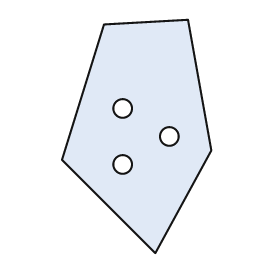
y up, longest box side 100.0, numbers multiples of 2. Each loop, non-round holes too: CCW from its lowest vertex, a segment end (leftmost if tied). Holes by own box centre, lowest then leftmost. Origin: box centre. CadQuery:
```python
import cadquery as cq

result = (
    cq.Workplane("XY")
    .moveTo(8.0, -50.0)
    .lineTo(32.0, -6.0)
    .lineTo(22.0, 50.0)
    .lineTo(-14.0, 48.0)
    .lineTo(-32.0, -10.0)
    .close()
    .moveTo(-6.0, -12.0)
    .circle(4.0)
    .moveTo(14.0, 0.0)
    .circle(4.0)
    .moveTo(-6.0, 12.0)
    .circle(4.0)
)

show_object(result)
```